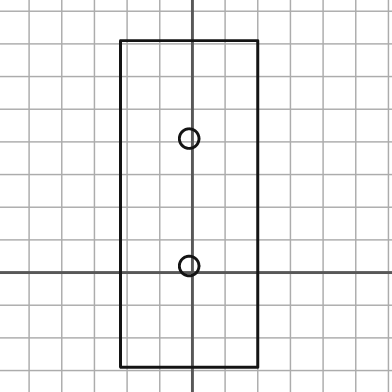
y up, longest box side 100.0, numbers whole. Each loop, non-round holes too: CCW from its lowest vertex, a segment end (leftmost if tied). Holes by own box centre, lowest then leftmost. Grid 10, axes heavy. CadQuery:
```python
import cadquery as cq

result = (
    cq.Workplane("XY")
    .moveTo(-22.0, -29.0)
    .lineTo(20.0, -29.0)
    .lineTo(20.0, 71.0)
    .lineTo(-22.0, 71.0)
    .close()
    .moveTo(-1.0, 2.0)
    .circle(3.0)
    .moveTo(-1.0, 41.0)
    .circle(3.0)
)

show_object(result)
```